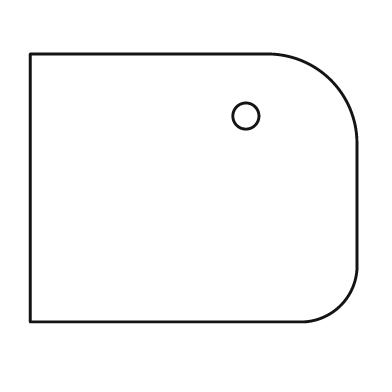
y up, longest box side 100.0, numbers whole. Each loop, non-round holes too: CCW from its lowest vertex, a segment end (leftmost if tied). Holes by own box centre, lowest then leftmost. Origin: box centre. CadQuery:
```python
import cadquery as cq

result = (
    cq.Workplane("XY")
    .moveTo(-50.0, -41.0)
    .lineTo(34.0, -41.0)
    .threePointArc((45.0, -36.0), (50.0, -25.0))
    .lineTo(50.0, 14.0)
    .threePointArc((42.0, 33.0), (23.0, 41.0))
    .lineTo(-50.0, 41.0)
    .close()
    .moveTo(16.0, 22.0)
    .circle(4.0)
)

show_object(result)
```